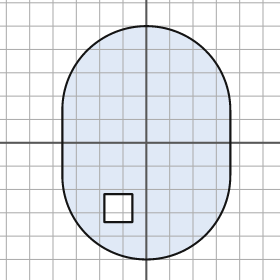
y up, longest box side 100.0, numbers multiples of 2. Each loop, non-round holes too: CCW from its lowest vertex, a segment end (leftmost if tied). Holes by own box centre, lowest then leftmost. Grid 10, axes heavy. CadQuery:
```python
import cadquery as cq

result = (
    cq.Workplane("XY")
    .moveTo(-36.0, -14.0)
    .threePointArc((0.0, -50.0), (36.0, -14.0))
    .lineTo(36.0, 14.0)
    .threePointArc((0.0, 50.0), (-36.0, 14.0))
    .close()
    .moveTo(-18.0, -34.0)
    .lineTo(-6.0, -34.0)
    .lineTo(-6.0, -22.0)
    .lineTo(-18.0, -22.0)
    .close()
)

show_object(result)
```